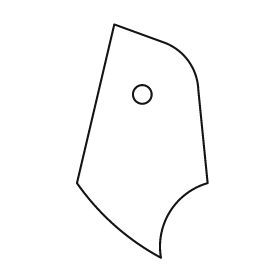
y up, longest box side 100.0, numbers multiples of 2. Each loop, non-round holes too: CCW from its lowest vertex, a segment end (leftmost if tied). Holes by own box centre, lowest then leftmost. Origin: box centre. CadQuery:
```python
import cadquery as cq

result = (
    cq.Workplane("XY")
    .moveTo(8.0, -50.0)
    .threePointArc((12.0, -30.0), (28.0, -18.0))
    .lineTo(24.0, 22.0)
    .threePointArc((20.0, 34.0), (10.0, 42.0))
    .lineTo(-12.0, 50.0)
    .lineTo(-28.0, -18.0)
    .threePointArc((-12.0, -36.0), (8.0, -50.0))
    .close()
    .moveTo(0.0, 20.0)
    .circle(4.0)
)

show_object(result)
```